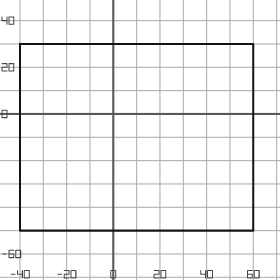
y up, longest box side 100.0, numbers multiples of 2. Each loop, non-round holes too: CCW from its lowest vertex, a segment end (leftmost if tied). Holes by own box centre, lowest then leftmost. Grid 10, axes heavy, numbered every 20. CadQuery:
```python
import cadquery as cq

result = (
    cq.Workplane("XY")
    .moveTo(-40.0, -50.0)
    .lineTo(60.0, -50.0)
    .lineTo(60.0, 30.0)
    .lineTo(-40.0, 30.0)
    .close()
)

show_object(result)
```